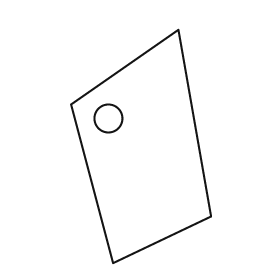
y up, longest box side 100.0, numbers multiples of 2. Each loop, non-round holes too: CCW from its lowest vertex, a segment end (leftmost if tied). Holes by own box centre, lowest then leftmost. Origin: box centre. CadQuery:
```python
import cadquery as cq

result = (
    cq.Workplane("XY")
    .moveTo(-12.0, -50.0)
    .lineTo(30.0, -30.0)
    .lineTo(16.0, 50.0)
    .lineTo(-30.0, 18.0)
    .close()
    .moveTo(-14.0, 12.0)
    .circle(6.0)
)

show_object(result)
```